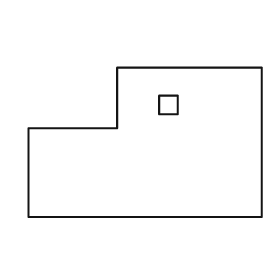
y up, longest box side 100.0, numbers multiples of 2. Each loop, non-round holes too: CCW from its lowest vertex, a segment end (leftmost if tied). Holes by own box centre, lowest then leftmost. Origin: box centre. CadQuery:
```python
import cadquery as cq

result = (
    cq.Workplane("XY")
    .moveTo(-50.0, -32.0)
    .lineTo(50.0, -32.0)
    .lineTo(50.0, 32.0)
    .lineTo(-12.0, 32.0)
    .lineTo(-12.0, 6.0)
    .lineTo(-50.0, 6.0)
    .close()
    .moveTo(6.0, 12.0)
    .lineTo(14.0, 12.0)
    .lineTo(14.0, 20.0)
    .lineTo(6.0, 20.0)
    .close()
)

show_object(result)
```